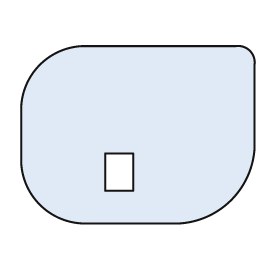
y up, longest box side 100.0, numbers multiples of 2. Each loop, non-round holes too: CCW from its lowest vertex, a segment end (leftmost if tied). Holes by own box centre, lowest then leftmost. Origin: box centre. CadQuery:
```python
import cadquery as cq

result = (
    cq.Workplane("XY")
    .moveTo(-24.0, -38.0)
    .lineTo(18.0, -38.0)
    .threePointArc((40.0, -28.0), (50.0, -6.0))
    .lineTo(50.0, 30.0)
    .threePointArc((48.0, 36.0), (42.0, 38.0))
    .lineTo(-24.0, 38.0)
    .threePointArc((-42.0, 30.0), (-50.0, 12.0))
    .lineTo(-50.0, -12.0)
    .threePointArc((-42.0, -30.0), (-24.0, -38.0))
    .close()
    .moveTo(-14.0, -24.0)
    .lineTo(-2.0, -24.0)
    .lineTo(-2.0, -8.0)
    .lineTo(-14.0, -8.0)
    .close()
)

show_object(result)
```